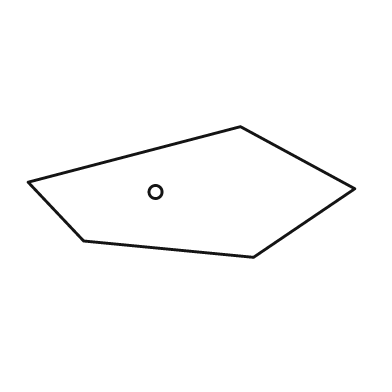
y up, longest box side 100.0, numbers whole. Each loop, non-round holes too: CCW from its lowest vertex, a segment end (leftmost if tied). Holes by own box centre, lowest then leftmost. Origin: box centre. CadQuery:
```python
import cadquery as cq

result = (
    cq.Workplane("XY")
    .moveTo(19.0, -20.0)
    .lineTo(50.0, 1.0)
    .lineTo(15.0, 20.0)
    .lineTo(-50.0, 3.0)
    .lineTo(-33.0, -15.0)
    .close()
    .moveTo(-11.0, 0.0)
    .circle(2.0)
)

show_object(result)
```